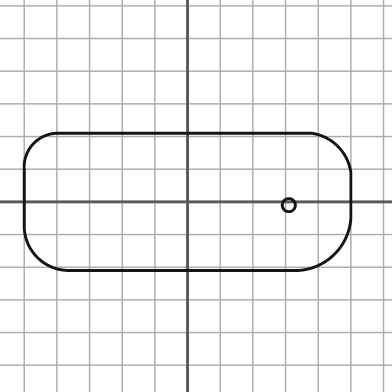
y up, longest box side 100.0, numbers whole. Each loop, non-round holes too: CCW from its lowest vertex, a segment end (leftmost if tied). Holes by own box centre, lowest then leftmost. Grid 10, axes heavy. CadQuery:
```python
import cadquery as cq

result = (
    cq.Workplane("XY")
    .moveTo(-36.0, -21.0)
    .lineTo(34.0, -21.0)
    .threePointArc((45.0, -16.0), (50.0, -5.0))
    .lineTo(50.0, 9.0)
    .threePointArc((46.0, 17.0), (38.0, 21.0))
    .lineTo(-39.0, 21.0)
    .threePointArc((-47.0, 18.0), (-50.0, 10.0))
    .lineTo(-50.0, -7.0)
    .threePointArc((-46.0, -17.0), (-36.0, -21.0))
    .close()
    .moveTo(31.0, -1.0)
    .circle(2.0)
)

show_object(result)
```